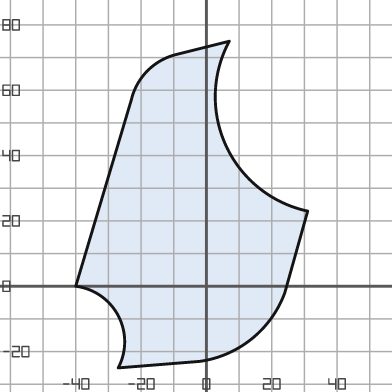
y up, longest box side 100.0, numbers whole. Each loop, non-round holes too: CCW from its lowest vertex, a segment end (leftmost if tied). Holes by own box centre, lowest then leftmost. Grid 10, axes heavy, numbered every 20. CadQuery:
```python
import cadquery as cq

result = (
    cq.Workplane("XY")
    .moveTo(-27.0, -25.0)
    .lineTo(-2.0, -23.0)
    .threePointArc((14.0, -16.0), (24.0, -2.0))
    .lineTo(31.0, 23.0)
    .threePointArc((6.0, 43.0), (7.0, 75.0))
    .lineTo(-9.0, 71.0)
    .threePointArc((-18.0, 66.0), (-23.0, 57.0))
    .lineTo(-40.0, 0.0)
    .threePointArc((-27.0, -9.0), (-27.0, -25.0))
    .close()
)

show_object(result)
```